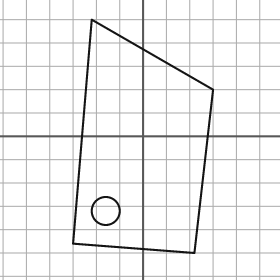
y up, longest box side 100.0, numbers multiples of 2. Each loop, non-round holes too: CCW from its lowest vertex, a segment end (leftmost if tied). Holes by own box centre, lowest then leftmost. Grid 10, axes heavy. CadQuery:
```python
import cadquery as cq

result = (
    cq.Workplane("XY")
    .moveTo(22.0, -50.0)
    .lineTo(30.0, 20.0)
    .lineTo(-22.0, 50.0)
    .lineTo(-30.0, -46.0)
    .close()
    .moveTo(-16.0, -32.0)
    .circle(6.0)
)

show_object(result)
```